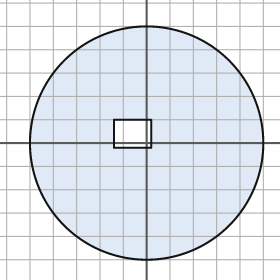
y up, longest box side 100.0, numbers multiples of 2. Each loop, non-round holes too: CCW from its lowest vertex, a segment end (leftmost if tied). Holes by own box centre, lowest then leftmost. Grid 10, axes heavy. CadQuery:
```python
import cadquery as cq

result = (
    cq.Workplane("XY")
    .moveTo(0.0, 0.0)
    .circle(50.0)
    .moveTo(-14.0, -2.0)
    .lineTo(2.0, -2.0)
    .lineTo(2.0, 10.0)
    .lineTo(-14.0, 10.0)
    .close()
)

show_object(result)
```